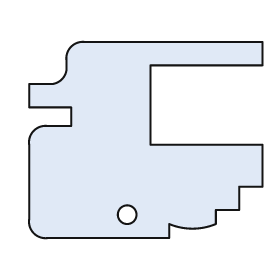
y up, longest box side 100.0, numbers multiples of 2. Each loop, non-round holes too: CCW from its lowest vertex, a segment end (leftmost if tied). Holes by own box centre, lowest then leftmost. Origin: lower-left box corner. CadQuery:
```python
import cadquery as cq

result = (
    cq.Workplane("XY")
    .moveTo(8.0, 0.0)
    .lineTo(60.0, 0.0)
    .lineTo(60.0, 6.0)
    .threePointArc((70.0, 4.0), (80.0, 6.0))
    .lineTo(80.0, 12.0)
    .lineTo(90.0, 12.0)
    .lineTo(90.0, 22.0)
    .lineTo(100.0, 22.0)
    .lineTo(100.0, 40.0)
    .lineTo(52.0, 40.0)
    .lineTo(52.0, 74.0)
    .lineTo(100.0, 74.0)
    .lineTo(100.0, 84.0)
    .lineTo(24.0, 84.0)
    .threePointArc((18.0, 82.0), (16.0, 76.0))
    .lineTo(16.0, 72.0)
    .threePointArc((14.0, 68.0), (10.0, 66.0))
    .lineTo(0.0, 66.0)
    .lineTo(0.0, 56.0)
    .lineTo(18.0, 56.0)
    .lineTo(18.0, 48.0)
    .lineTo(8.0, 48.0)
    .threePointArc((2.0, 46.0), (0.0, 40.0))
    .lineTo(0.0, 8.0)
    .threePointArc((2.0, 2.0), (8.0, 0.0))
    .close()
    .moveTo(42.0, 10.0)
    .circle(4.0)
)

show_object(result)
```